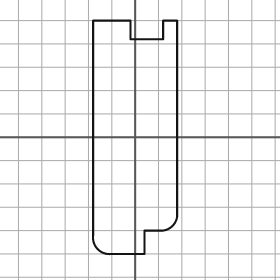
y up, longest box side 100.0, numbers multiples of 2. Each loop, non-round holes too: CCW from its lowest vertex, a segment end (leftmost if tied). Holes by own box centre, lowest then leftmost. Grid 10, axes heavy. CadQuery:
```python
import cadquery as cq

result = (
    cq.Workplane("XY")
    .moveTo(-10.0, -50.0)
    .lineTo(4.0, -50.0)
    .lineTo(4.0, -40.0)
    .lineTo(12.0, -40.0)
    .threePointArc((16.0, -38.0), (18.0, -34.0))
    .lineTo(18.0, 50.0)
    .lineTo(12.0, 50.0)
    .lineTo(12.0, 42.0)
    .lineTo(-2.0, 42.0)
    .lineTo(-2.0, 50.0)
    .lineTo(-18.0, 50.0)
    .lineTo(-18.0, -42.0)
    .threePointArc((-16.0, -48.0), (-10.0, -50.0))
    .close()
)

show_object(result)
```